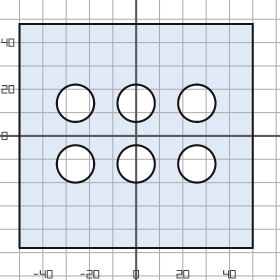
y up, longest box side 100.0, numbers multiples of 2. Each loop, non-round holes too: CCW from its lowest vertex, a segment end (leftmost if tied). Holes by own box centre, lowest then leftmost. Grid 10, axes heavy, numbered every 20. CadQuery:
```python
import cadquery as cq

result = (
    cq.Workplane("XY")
    .moveTo(-50.0, -48.0)
    .lineTo(50.0, -48.0)
    .lineTo(50.0, 48.0)
    .lineTo(-50.0, 48.0)
    .close()
    .moveTo(-26.0, -12.0)
    .circle(8.0)
    .moveTo(0.0, -12.0)
    .circle(8.0)
    .moveTo(26.0, -12.0)
    .circle(8.0)
    .moveTo(-26.0, 14.0)
    .circle(8.0)
    .moveTo(0.0, 14.0)
    .circle(8.0)
    .moveTo(26.0, 14.0)
    .circle(8.0)
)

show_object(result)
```